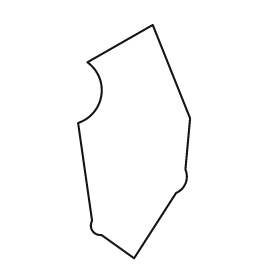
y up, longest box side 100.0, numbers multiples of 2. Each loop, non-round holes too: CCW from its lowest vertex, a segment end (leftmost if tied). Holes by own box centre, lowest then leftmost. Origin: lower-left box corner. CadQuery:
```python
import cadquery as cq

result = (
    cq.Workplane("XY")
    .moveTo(24.0, 0.0)
    .lineTo(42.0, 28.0)
    .threePointArc((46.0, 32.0), (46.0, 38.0))
    .lineTo(48.0, 60.0)
    .lineTo(32.0, 100.0)
    .lineTo(4.0, 84.0)
    .threePointArc((10.0, 70.0), (0.0, 58.0))
    .lineTo(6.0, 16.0)
    .threePointArc((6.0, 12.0), (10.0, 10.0))
    .close()
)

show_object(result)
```